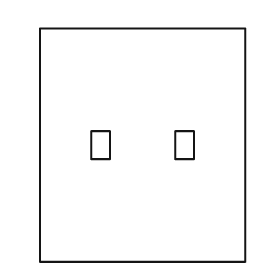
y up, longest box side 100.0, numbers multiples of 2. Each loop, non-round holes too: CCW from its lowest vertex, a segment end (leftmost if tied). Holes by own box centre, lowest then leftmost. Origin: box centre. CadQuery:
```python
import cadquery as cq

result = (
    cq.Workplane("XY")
    .moveTo(-44.0, -50.0)
    .lineTo(44.0, -50.0)
    .lineTo(44.0, 50.0)
    .lineTo(-44.0, 50.0)
    .close()
    .moveTo(-22.0, -6.0)
    .lineTo(-14.0, -6.0)
    .lineTo(-14.0, 6.0)
    .lineTo(-22.0, 6.0)
    .close()
    .moveTo(14.0, -6.0)
    .lineTo(22.0, -6.0)
    .lineTo(22.0, 6.0)
    .lineTo(14.0, 6.0)
    .close()
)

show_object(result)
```